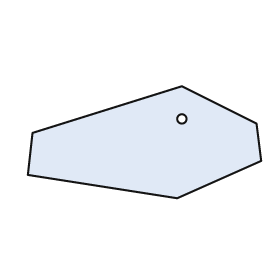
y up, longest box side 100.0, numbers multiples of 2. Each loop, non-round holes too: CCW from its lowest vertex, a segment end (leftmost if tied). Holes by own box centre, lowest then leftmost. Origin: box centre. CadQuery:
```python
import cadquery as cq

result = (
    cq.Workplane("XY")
    .moveTo(14.0, -24.0)
    .lineTo(50.0, -8.0)
    .lineTo(48.0, 8.0)
    .lineTo(16.0, 24.0)
    .lineTo(-48.0, 4.0)
    .lineTo(-50.0, -14.0)
    .close()
    .moveTo(16.0, 10.0)
    .circle(2.0)
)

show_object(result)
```